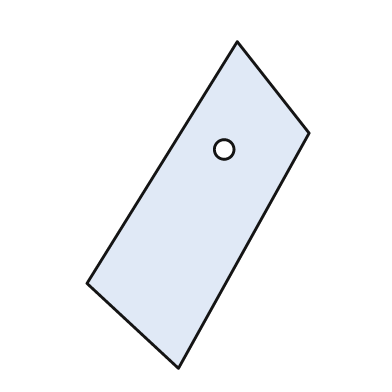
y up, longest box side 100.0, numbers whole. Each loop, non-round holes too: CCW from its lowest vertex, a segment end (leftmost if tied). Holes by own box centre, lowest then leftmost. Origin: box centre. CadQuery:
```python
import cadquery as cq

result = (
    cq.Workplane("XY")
    .moveTo(-6.0, -50.0)
    .lineTo(34.0, 22.0)
    .lineTo(12.0, 50.0)
    .lineTo(-34.0, -24.0)
    .close()
    .moveTo(8.0, 17.0)
    .circle(3.0)
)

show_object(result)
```